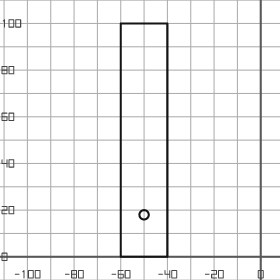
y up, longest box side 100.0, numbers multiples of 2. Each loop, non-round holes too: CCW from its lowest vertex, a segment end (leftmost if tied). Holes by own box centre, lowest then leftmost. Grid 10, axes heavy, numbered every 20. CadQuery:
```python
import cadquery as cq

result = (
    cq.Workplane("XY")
    .moveTo(-60.0, 0.0)
    .lineTo(-40.0, 0.0)
    .lineTo(-40.0, 100.0)
    .lineTo(-60.0, 100.0)
    .close()
    .moveTo(-50.0, 18.0)
    .circle(2.0)
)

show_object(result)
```